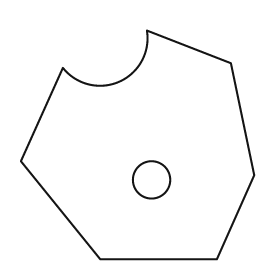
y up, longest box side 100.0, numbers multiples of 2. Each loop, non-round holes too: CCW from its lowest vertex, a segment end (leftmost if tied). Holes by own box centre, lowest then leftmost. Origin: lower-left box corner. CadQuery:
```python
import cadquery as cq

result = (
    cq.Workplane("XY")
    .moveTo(34.0, 0.0)
    .lineTo(84.0, 0.0)
    .lineTo(100.0, 36.0)
    .lineTo(90.0, 84.0)
    .lineTo(54.0, 98.0)
    .threePointArc((42.0, 76.0), (18.0, 82.0))
    .lineTo(0.0, 42.0)
    .close()
    .moveTo(56.0, 34.0)
    .circle(8.0)
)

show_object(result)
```